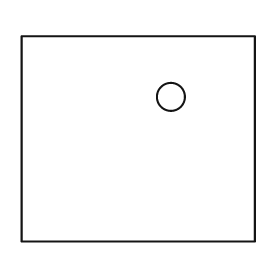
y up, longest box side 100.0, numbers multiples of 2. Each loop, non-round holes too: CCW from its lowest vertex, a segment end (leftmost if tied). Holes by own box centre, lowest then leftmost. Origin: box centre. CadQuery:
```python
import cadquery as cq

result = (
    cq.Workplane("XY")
    .moveTo(-50.0, -44.0)
    .lineTo(50.0, -44.0)
    .lineTo(50.0, 44.0)
    .lineTo(-50.0, 44.0)
    .close()
    .moveTo(14.0, 18.0)
    .circle(6.0)
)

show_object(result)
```